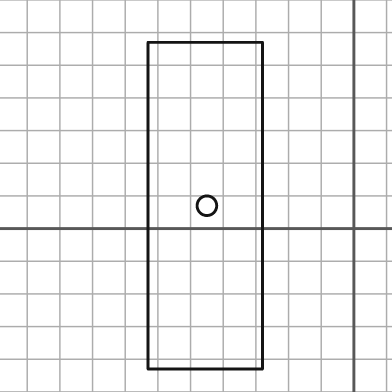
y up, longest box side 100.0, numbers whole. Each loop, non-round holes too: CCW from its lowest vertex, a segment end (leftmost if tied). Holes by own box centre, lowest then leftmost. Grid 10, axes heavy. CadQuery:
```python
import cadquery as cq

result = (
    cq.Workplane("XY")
    .moveTo(-63.0, -43.0)
    .lineTo(-28.0, -43.0)
    .lineTo(-28.0, 57.0)
    .lineTo(-63.0, 57.0)
    .close()
    .moveTo(-45.0, 7.0)
    .circle(3.0)
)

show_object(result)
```